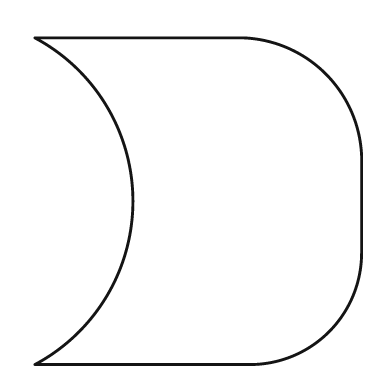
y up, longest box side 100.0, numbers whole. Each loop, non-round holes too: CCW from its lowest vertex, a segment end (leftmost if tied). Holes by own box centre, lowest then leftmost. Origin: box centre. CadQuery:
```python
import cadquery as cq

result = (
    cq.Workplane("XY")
    .moveTo(-50.0, -50.0)
    .lineTo(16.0, -50.0)
    .threePointArc((40.0, -40.0), (50.0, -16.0))
    .lineTo(50.0, 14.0)
    .threePointArc((39.0, 39.0), (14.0, 50.0))
    .lineTo(-50.0, 50.0)
    .threePointArc((-20.0, 0.0), (-50.0, -50.0))
    .close()
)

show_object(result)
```